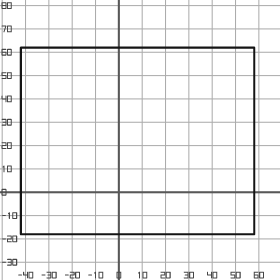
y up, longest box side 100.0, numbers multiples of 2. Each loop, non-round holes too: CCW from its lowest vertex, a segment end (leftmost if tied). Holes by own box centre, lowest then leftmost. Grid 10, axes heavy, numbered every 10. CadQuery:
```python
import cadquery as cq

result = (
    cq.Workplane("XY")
    .moveTo(-42.0, -18.0)
    .lineTo(58.0, -18.0)
    .lineTo(58.0, 62.0)
    .lineTo(-42.0, 62.0)
    .close()
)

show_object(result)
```